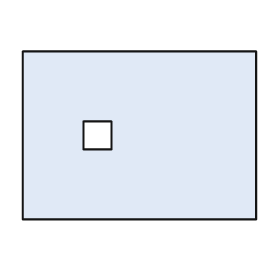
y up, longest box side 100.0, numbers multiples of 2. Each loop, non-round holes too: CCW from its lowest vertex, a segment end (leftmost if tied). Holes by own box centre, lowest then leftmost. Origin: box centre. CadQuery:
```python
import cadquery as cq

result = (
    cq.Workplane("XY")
    .moveTo(-50.0, -36.0)
    .lineTo(50.0, -36.0)
    .lineTo(50.0, 36.0)
    .lineTo(-50.0, 36.0)
    .close()
    .moveTo(-24.0, -6.0)
    .lineTo(-12.0, -6.0)
    .lineTo(-12.0, 6.0)
    .lineTo(-24.0, 6.0)
    .close()
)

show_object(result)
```